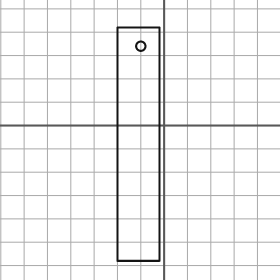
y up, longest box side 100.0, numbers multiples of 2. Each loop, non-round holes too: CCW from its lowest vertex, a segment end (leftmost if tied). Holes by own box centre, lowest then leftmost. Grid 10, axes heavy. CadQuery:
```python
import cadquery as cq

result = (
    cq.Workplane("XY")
    .moveTo(-20.0, -58.0)
    .lineTo(-2.0, -58.0)
    .lineTo(-2.0, 42.0)
    .lineTo(-20.0, 42.0)
    .close()
    .moveTo(-10.0, 34.0)
    .circle(2.0)
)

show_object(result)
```